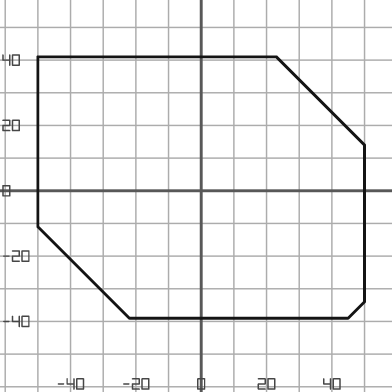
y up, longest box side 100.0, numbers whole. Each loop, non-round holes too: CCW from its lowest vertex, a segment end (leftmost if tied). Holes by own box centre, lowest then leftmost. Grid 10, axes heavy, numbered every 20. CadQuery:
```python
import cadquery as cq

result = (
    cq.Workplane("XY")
    .moveTo(-22.0, -39.0)
    .lineTo(45.0, -39.0)
    .lineTo(50.0, -34.0)
    .lineTo(50.0, 14.0)
    .lineTo(23.0, 41.0)
    .lineTo(-50.0, 41.0)
    .lineTo(-50.0, -11.0)
    .close()
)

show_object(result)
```